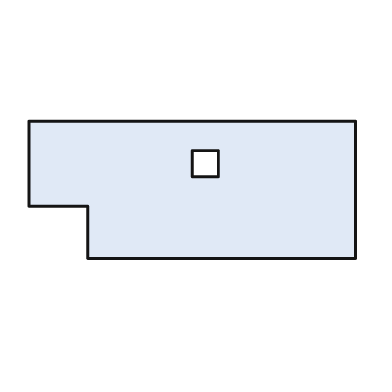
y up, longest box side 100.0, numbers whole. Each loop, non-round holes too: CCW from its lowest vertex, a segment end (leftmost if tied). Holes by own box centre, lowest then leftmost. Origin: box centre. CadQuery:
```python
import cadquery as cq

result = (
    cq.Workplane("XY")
    .moveTo(-32.0, -21.0)
    .lineTo(50.0, -21.0)
    .lineTo(50.0, 21.0)
    .lineTo(-50.0, 21.0)
    .lineTo(-50.0, -5.0)
    .lineTo(-32.0, -5.0)
    .close()
    .moveTo(0.0, 4.0)
    .lineTo(8.0, 4.0)
    .lineTo(8.0, 12.0)
    .lineTo(0.0, 12.0)
    .close()
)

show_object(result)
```